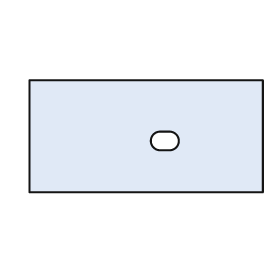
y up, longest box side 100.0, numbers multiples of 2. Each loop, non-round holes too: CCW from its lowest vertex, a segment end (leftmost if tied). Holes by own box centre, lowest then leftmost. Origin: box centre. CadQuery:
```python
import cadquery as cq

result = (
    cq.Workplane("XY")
    .moveTo(-50.0, -24.0)
    .lineTo(50.0, -24.0)
    .lineTo(50.0, 24.0)
    .lineTo(-50.0, 24.0)
    .close()
    .moveTo(6.0, -6.0)
    .lineTo(10.0, -6.0)
    .threePointArc((14.0, -2.0), (10.0, 2.0))
    .lineTo(6.0, 2.0)
    .threePointArc((2.0, -2.0), (6.0, -6.0))
    .close()
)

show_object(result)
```